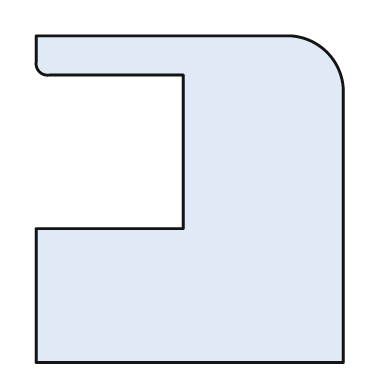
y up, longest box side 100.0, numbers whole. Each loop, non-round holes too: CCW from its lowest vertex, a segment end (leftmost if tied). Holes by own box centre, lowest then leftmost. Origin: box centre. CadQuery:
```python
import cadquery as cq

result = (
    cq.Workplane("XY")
    .moveTo(-47.0, -50.0)
    .lineTo(47.0, -50.0)
    .lineTo(47.0, 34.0)
    .threePointArc((42.0, 45.0), (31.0, 50.0))
    .lineTo(-47.0, 50.0)
    .lineTo(-47.0, 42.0)
    .threePointArc((-46.0, 39.0), (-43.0, 38.0))
    .lineTo(-2.0, 38.0)
    .lineTo(-2.0, -9.0)
    .lineTo(-47.0, -9.0)
    .close()
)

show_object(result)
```